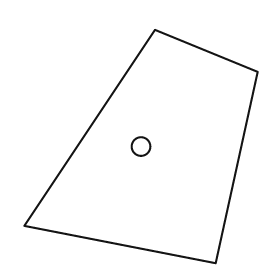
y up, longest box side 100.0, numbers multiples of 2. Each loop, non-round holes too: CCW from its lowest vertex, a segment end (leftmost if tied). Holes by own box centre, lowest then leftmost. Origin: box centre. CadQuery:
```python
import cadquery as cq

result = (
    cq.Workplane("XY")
    .moveTo(32.0, -50.0)
    .lineTo(50.0, 32.0)
    .lineTo(6.0, 50.0)
    .lineTo(-50.0, -34.0)
    .close()
    .moveTo(0.0, 0.0)
    .circle(4.0)
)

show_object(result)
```